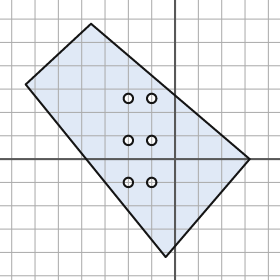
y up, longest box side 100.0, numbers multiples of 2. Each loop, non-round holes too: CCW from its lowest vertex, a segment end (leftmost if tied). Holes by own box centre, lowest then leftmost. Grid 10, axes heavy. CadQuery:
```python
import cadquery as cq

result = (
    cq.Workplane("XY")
    .moveTo(-4.0, -42.0)
    .lineTo(32.0, 0.0)
    .lineTo(-36.0, 58.0)
    .lineTo(-64.0, 32.0)
    .close()
    .moveTo(-20.0, -10.0)
    .circle(2.0)
    .moveTo(-10.0, -10.0)
    .circle(2.0)
    .moveTo(-20.0, 8.0)
    .circle(2.0)
    .moveTo(-10.0, 8.0)
    .circle(2.0)
    .moveTo(-20.0, 26.0)
    .circle(2.0)
    .moveTo(-10.0, 26.0)
    .circle(2.0)
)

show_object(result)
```